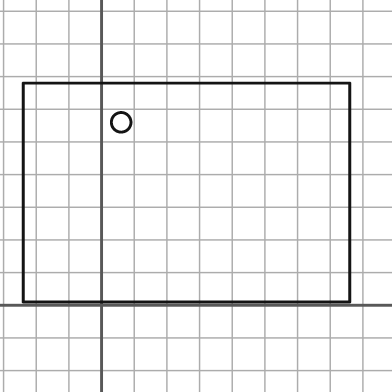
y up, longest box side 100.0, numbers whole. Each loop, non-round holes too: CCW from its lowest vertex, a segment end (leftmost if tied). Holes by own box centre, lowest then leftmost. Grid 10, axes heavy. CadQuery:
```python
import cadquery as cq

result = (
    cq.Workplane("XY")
    .moveTo(-24.0, 1.0)
    .lineTo(76.0, 1.0)
    .lineTo(76.0, 68.0)
    .lineTo(-24.0, 68.0)
    .close()
    .moveTo(6.0, 56.0)
    .circle(3.0)
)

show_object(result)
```